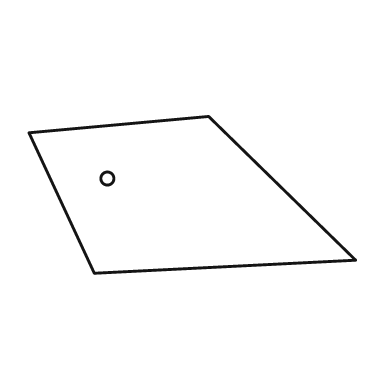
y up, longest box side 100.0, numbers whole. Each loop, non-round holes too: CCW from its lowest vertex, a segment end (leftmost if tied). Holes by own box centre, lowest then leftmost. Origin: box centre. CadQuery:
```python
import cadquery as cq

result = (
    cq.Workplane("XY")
    .moveTo(-30.0, -24.0)
    .lineTo(50.0, -20.0)
    .lineTo(5.0, 24.0)
    .lineTo(-50.0, 19.0)
    .close()
    .moveTo(-26.0, 5.0)
    .circle(2.0)
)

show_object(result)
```